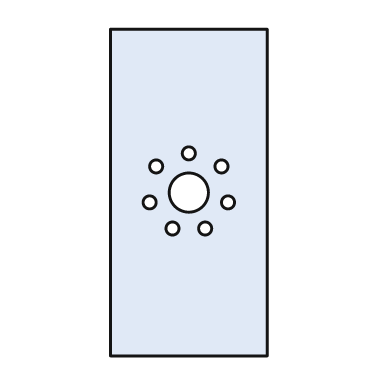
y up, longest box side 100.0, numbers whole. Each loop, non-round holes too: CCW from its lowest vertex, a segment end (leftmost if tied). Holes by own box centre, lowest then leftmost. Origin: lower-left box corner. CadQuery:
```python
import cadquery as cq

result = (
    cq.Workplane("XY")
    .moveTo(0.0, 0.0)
    .lineTo(48.0, 0.0)
    .lineTo(48.0, 100.0)
    .lineTo(0.0, 100.0)
    .close()
    .moveTo(19.0, 39.0)
    .circle(2.0)
    .moveTo(29.0, 39.0)
    .circle(2.0)
    .moveTo(12.0, 47.0)
    .circle(2.0)
    .moveTo(36.0, 47.0)
    .circle(2.0)
    .moveTo(24.0, 50.0)
    .circle(6.0)
    .moveTo(14.0, 58.0)
    .circle(2.0)
    .moveTo(34.0, 58.0)
    .circle(2.0)
    .moveTo(24.0, 62.0)
    .circle(2.0)
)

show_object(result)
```